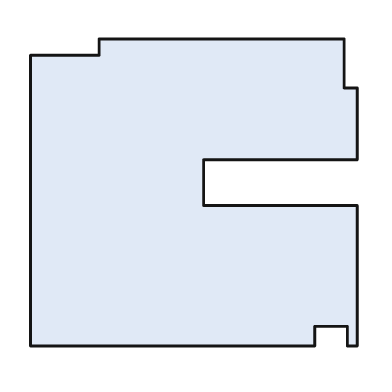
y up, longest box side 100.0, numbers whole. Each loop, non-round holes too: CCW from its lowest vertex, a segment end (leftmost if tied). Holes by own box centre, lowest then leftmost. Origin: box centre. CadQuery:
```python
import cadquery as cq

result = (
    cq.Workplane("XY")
    .moveTo(-50.0, -47.0)
    .lineTo(37.0, -47.0)
    .lineTo(37.0, -41.0)
    .lineTo(47.0, -41.0)
    .lineTo(47.0, -47.0)
    .lineTo(50.0, -47.0)
    .lineTo(50.0, -4.0)
    .lineTo(3.0, -4.0)
    .lineTo(3.0, 10.0)
    .lineTo(50.0, 10.0)
    .lineTo(50.0, 32.0)
    .lineTo(46.0, 32.0)
    .lineTo(46.0, 47.0)
    .lineTo(-29.0, 47.0)
    .lineTo(-29.0, 42.0)
    .lineTo(-50.0, 42.0)
    .close()
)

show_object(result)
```